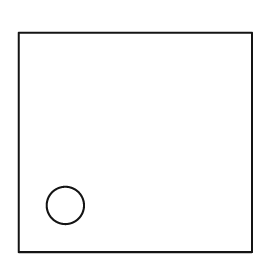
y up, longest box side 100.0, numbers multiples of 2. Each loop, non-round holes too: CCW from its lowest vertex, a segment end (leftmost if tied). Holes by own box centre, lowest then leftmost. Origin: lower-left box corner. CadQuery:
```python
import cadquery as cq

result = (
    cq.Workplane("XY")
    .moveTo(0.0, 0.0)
    .lineTo(100.0, 0.0)
    .lineTo(100.0, 94.0)
    .lineTo(0.0, 94.0)
    .close()
    .moveTo(20.0, 20.0)
    .circle(8.0)
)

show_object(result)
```